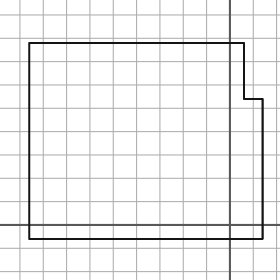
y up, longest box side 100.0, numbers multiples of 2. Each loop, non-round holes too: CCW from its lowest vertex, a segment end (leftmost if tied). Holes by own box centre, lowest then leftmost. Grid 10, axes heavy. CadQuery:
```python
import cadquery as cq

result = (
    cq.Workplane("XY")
    .moveTo(-86.0, -6.0)
    .lineTo(14.0, -6.0)
    .lineTo(14.0, 54.0)
    .lineTo(6.0, 54.0)
    .lineTo(6.0, 78.0)
    .lineTo(-86.0, 78.0)
    .close()
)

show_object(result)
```